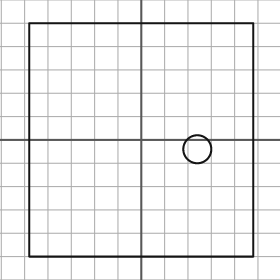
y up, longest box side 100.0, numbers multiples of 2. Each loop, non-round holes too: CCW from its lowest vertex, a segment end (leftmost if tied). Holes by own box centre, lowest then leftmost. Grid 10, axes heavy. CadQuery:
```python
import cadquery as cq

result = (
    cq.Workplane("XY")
    .moveTo(-48.0, -50.0)
    .lineTo(48.0, -50.0)
    .lineTo(48.0, 50.0)
    .lineTo(-48.0, 50.0)
    .close()
    .moveTo(24.0, -4.0)
    .circle(6.0)
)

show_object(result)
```